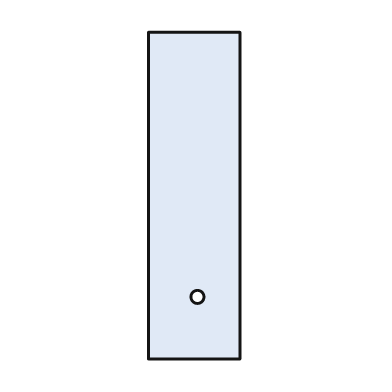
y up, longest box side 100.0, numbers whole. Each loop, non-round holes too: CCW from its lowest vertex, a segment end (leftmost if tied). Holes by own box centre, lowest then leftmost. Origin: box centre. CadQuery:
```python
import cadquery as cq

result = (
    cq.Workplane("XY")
    .moveTo(-14.0, -50.0)
    .lineTo(14.0, -50.0)
    .lineTo(14.0, 50.0)
    .lineTo(-14.0, 50.0)
    .close()
    .moveTo(1.0, -31.0)
    .circle(2.0)
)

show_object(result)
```